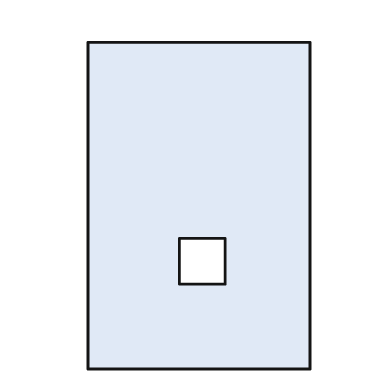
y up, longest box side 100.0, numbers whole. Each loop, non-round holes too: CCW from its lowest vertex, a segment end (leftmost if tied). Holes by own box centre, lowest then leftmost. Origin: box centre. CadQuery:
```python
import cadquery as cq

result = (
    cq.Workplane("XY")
    .moveTo(-34.0, -50.0)
    .lineTo(34.0, -50.0)
    .lineTo(34.0, 50.0)
    .lineTo(-34.0, 50.0)
    .close()
    .moveTo(-6.0, -24.0)
    .lineTo(8.0, -24.0)
    .lineTo(8.0, -10.0)
    .lineTo(-6.0, -10.0)
    .close()
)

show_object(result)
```